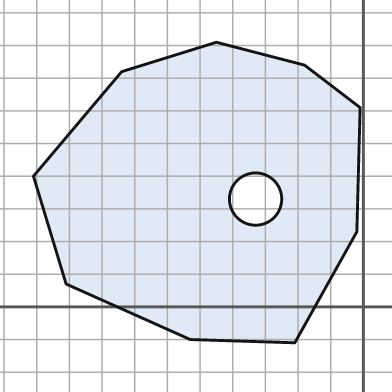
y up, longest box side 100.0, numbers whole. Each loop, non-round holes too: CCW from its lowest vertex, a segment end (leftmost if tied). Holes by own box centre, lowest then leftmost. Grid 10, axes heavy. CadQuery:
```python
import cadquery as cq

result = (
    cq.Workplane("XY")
    .moveTo(-21.0, -11.0)
    .lineTo(-2.0, 23.0)
    .lineTo(-1.0, 61.0)
    .lineTo(-18.0, 74.0)
    .lineTo(-45.0, 81.0)
    .lineTo(-74.0, 72.0)
    .lineTo(-101.0, 40.0)
    .lineTo(-91.0, 7.0)
    .lineTo(-53.0, -10.0)
    .close()
    .moveTo(-33.0, 33.0)
    .circle(8.0)
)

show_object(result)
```